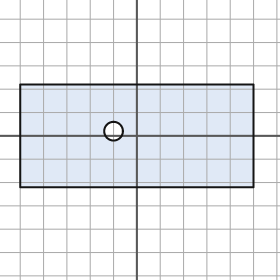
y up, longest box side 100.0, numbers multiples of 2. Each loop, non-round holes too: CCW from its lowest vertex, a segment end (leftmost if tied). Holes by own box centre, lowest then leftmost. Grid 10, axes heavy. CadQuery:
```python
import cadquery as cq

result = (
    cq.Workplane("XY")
    .moveTo(-50.0, -22.0)
    .lineTo(50.0, -22.0)
    .lineTo(50.0, 22.0)
    .lineTo(-50.0, 22.0)
    .close()
    .moveTo(-10.0, 2.0)
    .circle(4.0)
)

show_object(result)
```